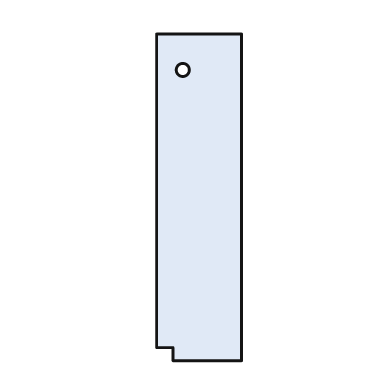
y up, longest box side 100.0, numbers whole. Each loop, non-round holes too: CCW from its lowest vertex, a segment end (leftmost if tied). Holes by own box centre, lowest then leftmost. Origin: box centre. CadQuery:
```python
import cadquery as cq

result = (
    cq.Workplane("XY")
    .moveTo(-8.0, -50.0)
    .lineTo(13.0, -50.0)
    .lineTo(13.0, 50.0)
    .lineTo(-13.0, 50.0)
    .lineTo(-13.0, -46.0)
    .lineTo(-8.0, -46.0)
    .close()
    .moveTo(-5.0, 39.0)
    .circle(2.0)
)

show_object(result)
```